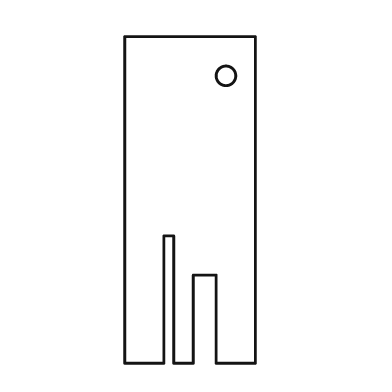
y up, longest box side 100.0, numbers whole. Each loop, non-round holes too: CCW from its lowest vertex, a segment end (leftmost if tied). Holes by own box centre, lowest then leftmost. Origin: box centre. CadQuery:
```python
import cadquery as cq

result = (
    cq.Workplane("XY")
    .moveTo(-20.0, -50.0)
    .lineTo(-8.0, -50.0)
    .lineTo(-8.0, -11.0)
    .lineTo(-5.0, -11.0)
    .lineTo(-5.0, -50.0)
    .lineTo(1.0, -50.0)
    .lineTo(1.0, -23.0)
    .lineTo(8.0, -23.0)
    .lineTo(8.0, -50.0)
    .lineTo(20.0, -50.0)
    .lineTo(20.0, 50.0)
    .lineTo(-20.0, 50.0)
    .close()
    .moveTo(11.0, 38.0)
    .circle(3.0)
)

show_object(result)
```